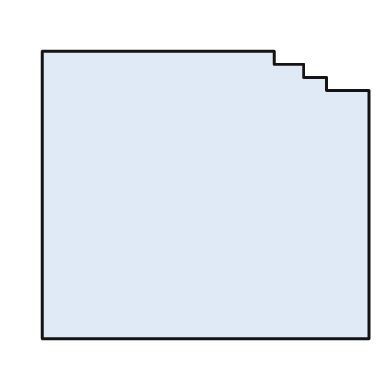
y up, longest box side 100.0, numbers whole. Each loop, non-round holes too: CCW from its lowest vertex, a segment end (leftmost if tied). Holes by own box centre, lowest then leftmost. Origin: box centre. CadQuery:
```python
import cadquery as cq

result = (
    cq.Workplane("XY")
    .moveTo(-50.0, -44.0)
    .lineTo(50.0, -44.0)
    .lineTo(50.0, 32.0)
    .lineTo(37.0, 32.0)
    .lineTo(37.0, 36.0)
    .lineTo(30.0, 36.0)
    .lineTo(30.0, 40.0)
    .lineTo(21.0, 40.0)
    .lineTo(21.0, 44.0)
    .lineTo(-50.0, 44.0)
    .close()
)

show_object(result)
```